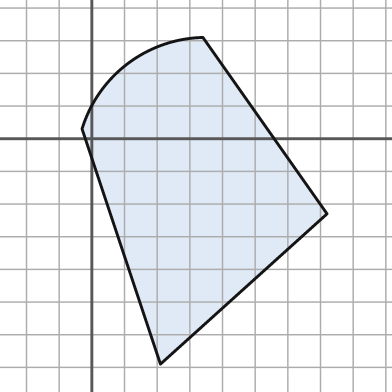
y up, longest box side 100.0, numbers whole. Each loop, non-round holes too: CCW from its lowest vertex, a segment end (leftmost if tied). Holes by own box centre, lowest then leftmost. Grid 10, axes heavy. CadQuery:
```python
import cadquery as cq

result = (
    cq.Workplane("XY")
    .moveTo(21.0, -69.0)
    .lineTo(72.0, -23.0)
    .lineTo(34.0, 31.0)
    .threePointArc((11.0, 23.0), (-3.0, 3.0))
    .close()
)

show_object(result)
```